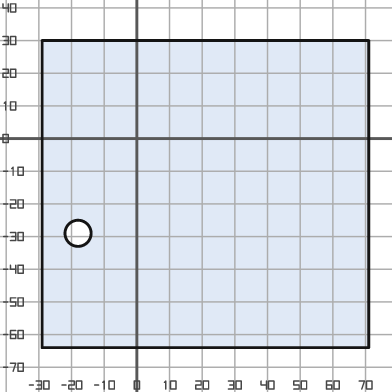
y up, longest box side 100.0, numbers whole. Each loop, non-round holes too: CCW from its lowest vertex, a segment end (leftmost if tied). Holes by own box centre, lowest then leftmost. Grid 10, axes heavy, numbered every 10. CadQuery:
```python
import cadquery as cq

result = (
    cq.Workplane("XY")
    .moveTo(-29.0, -64.0)
    .lineTo(71.0, -64.0)
    .lineTo(71.0, 30.0)
    .lineTo(-29.0, 30.0)
    .close()
    .moveTo(-18.0, -29.0)
    .circle(4.0)
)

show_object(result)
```